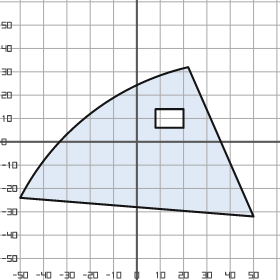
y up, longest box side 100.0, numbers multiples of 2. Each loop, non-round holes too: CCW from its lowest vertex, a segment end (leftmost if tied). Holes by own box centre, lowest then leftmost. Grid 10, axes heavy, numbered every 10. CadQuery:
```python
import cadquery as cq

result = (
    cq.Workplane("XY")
    .moveTo(50.0, -32.0)
    .lineTo(22.0, 32.0)
    .threePointArc((-20.0, 12.0), (-50.0, -24.0))
    .close()
    .moveTo(8.0, 6.0)
    .lineTo(20.0, 6.0)
    .lineTo(20.0, 14.0)
    .lineTo(8.0, 14.0)
    .close()
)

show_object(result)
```